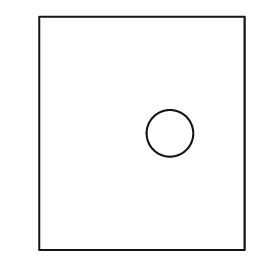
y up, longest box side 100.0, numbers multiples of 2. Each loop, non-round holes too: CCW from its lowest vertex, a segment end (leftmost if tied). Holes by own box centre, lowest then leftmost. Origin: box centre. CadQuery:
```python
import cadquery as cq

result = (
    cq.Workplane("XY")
    .moveTo(-44.0, -50.0)
    .lineTo(44.0, -50.0)
    .lineTo(44.0, 50.0)
    .lineTo(-44.0, 50.0)
    .close()
    .moveTo(12.0, 0.0)
    .circle(10.0)
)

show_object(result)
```